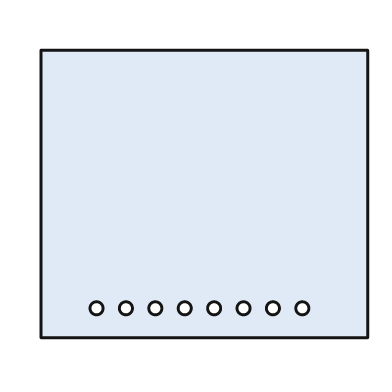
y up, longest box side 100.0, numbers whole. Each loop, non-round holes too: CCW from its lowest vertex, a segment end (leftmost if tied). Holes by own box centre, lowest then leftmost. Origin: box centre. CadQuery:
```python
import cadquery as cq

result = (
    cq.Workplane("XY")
    .moveTo(-50.0, -44.0)
    .lineTo(50.0, -44.0)
    .lineTo(50.0, 44.0)
    .lineTo(-50.0, 44.0)
    .close()
    .moveTo(-33.0, -35.0)
    .circle(2.0)
    .moveTo(-24.0, -35.0)
    .circle(2.0)
    .moveTo(-15.0, -35.0)
    .circle(2.0)
    .moveTo(-6.0, -35.0)
    .circle(2.0)
    .moveTo(3.0, -35.0)
    .circle(2.0)
    .moveTo(12.0, -35.0)
    .circle(2.0)
    .moveTo(21.0, -35.0)
    .circle(2.0)
    .moveTo(30.0, -35.0)
    .circle(2.0)
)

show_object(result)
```